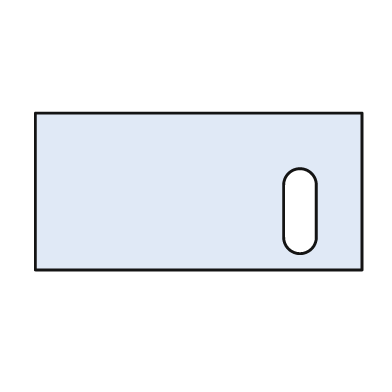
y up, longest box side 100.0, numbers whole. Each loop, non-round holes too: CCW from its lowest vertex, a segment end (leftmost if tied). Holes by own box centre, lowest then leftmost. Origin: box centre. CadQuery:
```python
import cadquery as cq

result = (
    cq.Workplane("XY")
    .moveTo(-50.0, -24.0)
    .lineTo(50.0, -24.0)
    .lineTo(50.0, 24.0)
    .lineTo(-50.0, 24.0)
    .close()
    .moveTo(26.0, -14.0)
    .threePointArc((31.0, -19.0), (36.0, -14.0))
    .lineTo(36.0, 2.0)
    .threePointArc((31.0, 7.0), (26.0, 2.0))
    .close()
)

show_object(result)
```